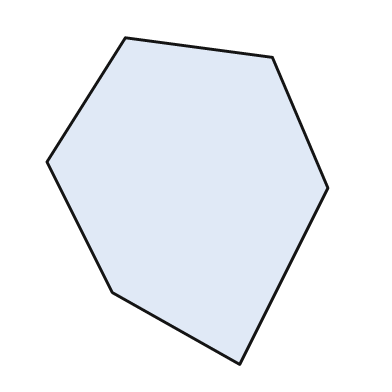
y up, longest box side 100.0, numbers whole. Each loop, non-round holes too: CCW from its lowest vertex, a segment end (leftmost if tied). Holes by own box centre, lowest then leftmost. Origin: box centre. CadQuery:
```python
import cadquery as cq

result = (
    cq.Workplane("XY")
    .moveTo(16.0, -50.0)
    .lineTo(43.0, 4.0)
    .lineTo(26.0, 44.0)
    .lineTo(-19.0, 50.0)
    .lineTo(-43.0, 12.0)
    .lineTo(-23.0, -28.0)
    .close()
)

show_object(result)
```